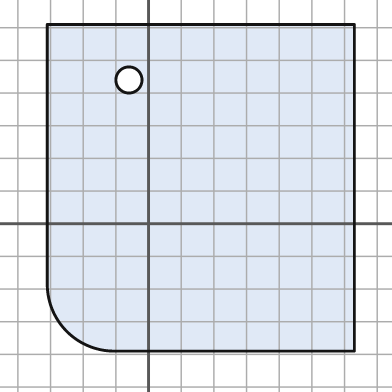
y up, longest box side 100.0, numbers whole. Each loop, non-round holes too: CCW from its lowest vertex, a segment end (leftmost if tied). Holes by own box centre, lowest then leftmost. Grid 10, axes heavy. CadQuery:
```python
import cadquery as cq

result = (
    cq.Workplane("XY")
    .moveTo(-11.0, -39.0)
    .lineTo(63.0, -39.0)
    .lineTo(63.0, 61.0)
    .lineTo(-31.0, 61.0)
    .lineTo(-31.0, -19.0)
    .threePointArc((-25.0, -33.0), (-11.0, -39.0))
    .close()
    .moveTo(-6.0, 44.0)
    .circle(4.0)
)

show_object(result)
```